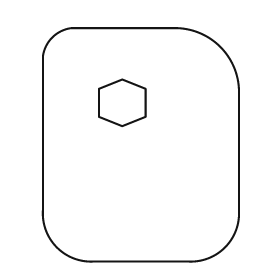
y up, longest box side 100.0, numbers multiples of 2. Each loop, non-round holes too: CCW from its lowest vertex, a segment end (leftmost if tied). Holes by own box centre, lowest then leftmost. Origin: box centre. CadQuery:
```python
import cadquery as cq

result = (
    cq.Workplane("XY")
    .moveTo(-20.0, -50.0)
    .lineTo(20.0, -50.0)
    .threePointArc((36.0, -44.0), (42.0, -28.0))
    .lineTo(42.0, 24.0)
    .threePointArc((34.0, 42.0), (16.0, 50.0))
    .lineTo(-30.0, 50.0)
    .threePointArc((-38.0, 46.0), (-42.0, 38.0))
    .lineTo(-42.0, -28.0)
    .threePointArc((-36.0, -44.0), (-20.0, -50.0))
    .close()
    .moveTo(-8.0, 8.0)
    .lineTo(2.0, 12.0)
    .lineTo(2.0, 24.0)
    .lineTo(-8.0, 28.0)
    .lineTo(-18.0, 24.0)
    .lineTo(-18.0, 12.0)
    .close()
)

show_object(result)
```